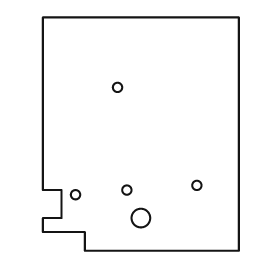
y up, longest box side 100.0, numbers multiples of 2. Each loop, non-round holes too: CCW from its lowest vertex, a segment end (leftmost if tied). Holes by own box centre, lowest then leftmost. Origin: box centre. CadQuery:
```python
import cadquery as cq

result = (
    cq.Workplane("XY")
    .moveTo(-24.0, -50.0)
    .lineTo(42.0, -50.0)
    .lineTo(42.0, 50.0)
    .lineTo(-42.0, 50.0)
    .lineTo(-42.0, -24.0)
    .lineTo(-34.0, -24.0)
    .lineTo(-34.0, -36.0)
    .lineTo(-42.0, -36.0)
    .lineTo(-42.0, -42.0)
    .lineTo(-24.0, -42.0)
    .close()
    .moveTo(0.0, -36.0)
    .circle(4.0)
    .moveTo(-28.0, -26.0)
    .circle(2.0)
    .moveTo(-6.0, -24.0)
    .circle(2.0)
    .moveTo(24.0, -22.0)
    .circle(2.0)
    .moveTo(-10.0, 20.0)
    .circle(2.0)
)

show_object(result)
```